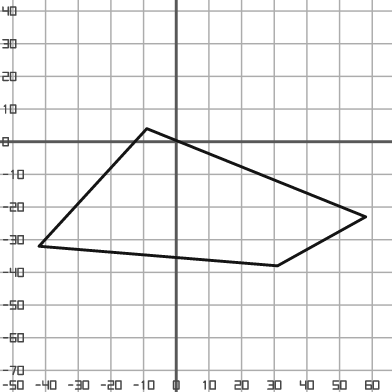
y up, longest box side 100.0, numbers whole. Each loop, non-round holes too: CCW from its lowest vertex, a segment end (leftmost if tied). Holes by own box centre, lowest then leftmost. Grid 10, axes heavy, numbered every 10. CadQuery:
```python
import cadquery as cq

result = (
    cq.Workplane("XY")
    .moveTo(31.0, -38.0)
    .lineTo(58.0, -23.0)
    .lineTo(-9.0, 4.0)
    .lineTo(-42.0, -32.0)
    .close()
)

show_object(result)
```